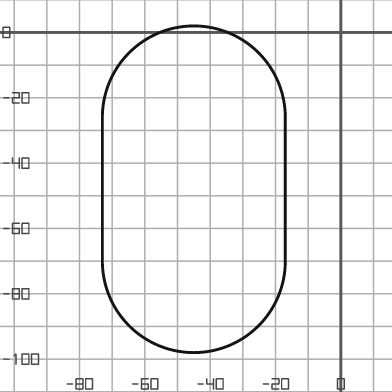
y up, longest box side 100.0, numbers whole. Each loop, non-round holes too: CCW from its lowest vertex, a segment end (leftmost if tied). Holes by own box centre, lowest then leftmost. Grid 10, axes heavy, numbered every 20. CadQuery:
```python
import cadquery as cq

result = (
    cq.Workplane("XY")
    .moveTo(-73.0, -70.0)
    .threePointArc((-45.0, -98.0), (-17.0, -70.0))
    .lineTo(-17.0, -26.0)
    .threePointArc((-45.0, 2.0), (-73.0, -26.0))
    .close()
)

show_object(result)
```